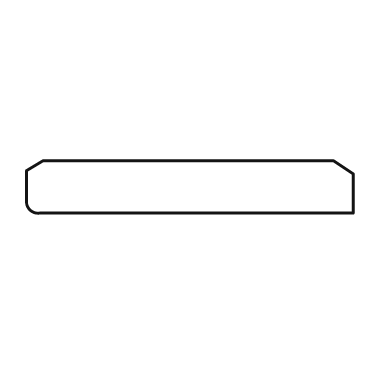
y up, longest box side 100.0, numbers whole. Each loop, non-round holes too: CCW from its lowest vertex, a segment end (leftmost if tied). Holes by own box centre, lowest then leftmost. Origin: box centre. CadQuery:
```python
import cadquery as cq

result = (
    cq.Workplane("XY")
    .moveTo(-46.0, -8.0)
    .lineTo(50.0, -8.0)
    .lineTo(50.0, 4.0)
    .lineTo(44.0, 8.0)
    .lineTo(-45.0, 8.0)
    .lineTo(-50.0, 5.0)
    .lineTo(-50.0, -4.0)
    .threePointArc((-49.0, -7.0), (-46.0, -8.0))
    .close()
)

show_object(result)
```